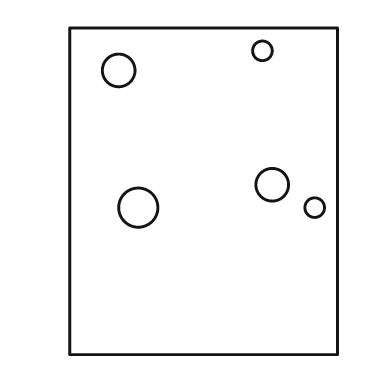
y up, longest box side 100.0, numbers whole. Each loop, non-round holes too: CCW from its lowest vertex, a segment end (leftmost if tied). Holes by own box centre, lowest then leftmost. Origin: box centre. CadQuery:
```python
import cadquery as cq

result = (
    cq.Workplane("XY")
    .moveTo(-41.0, -50.0)
    .lineTo(41.0, -50.0)
    .lineTo(41.0, 50.0)
    .lineTo(-41.0, 50.0)
    .close()
    .moveTo(-20.0, -5.0)
    .circle(6.0)
    .moveTo(34.0, -5.0)
    .circle(3.0)
    .moveTo(21.0, 2.0)
    .circle(5.0)
    .moveTo(-26.0, 37.0)
    .circle(5.0)
    .moveTo(18.0, 43.0)
    .circle(3.0)
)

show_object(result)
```